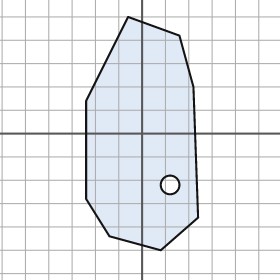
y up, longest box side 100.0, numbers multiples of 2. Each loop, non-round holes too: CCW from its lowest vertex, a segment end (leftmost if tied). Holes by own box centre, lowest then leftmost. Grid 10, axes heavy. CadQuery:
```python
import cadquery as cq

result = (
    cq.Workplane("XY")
    .moveTo(8.0, -50.0)
    .lineTo(24.0, -36.0)
    .lineTo(22.0, 20.0)
    .lineTo(16.0, 42.0)
    .lineTo(-6.0, 50.0)
    .lineTo(-24.0, 14.0)
    .lineTo(-24.0, -28.0)
    .lineTo(-14.0, -44.0)
    .close()
    .moveTo(12.0, -22.0)
    .circle(4.0)
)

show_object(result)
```